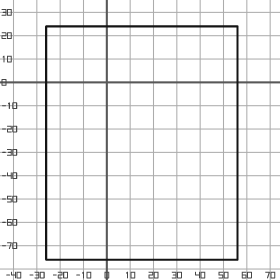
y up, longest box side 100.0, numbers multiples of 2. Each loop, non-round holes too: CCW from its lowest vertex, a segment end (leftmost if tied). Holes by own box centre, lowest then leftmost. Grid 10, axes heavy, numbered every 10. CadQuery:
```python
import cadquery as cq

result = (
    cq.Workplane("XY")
    .moveTo(-26.0, -76.0)
    .lineTo(56.0, -76.0)
    .lineTo(56.0, 24.0)
    .lineTo(-26.0, 24.0)
    .close()
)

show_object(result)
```